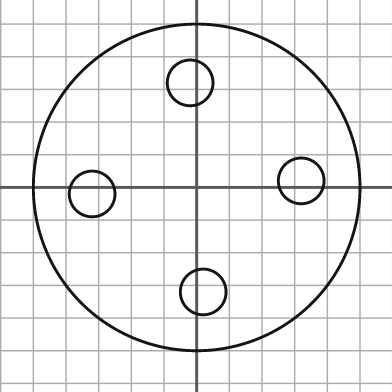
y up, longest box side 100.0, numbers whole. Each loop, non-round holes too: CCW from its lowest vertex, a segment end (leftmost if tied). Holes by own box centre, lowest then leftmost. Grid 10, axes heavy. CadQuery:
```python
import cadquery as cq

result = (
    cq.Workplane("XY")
    .moveTo(0.0, 0.0)
    .circle(50.0)
    .moveTo(2.0, -32.0)
    .circle(7.0)
    .moveTo(-32.0, -2.0)
    .circle(7.0)
    .moveTo(32.0, 2.0)
    .circle(7.0)
    .moveTo(-2.0, 32.0)
    .circle(7.0)
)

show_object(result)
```